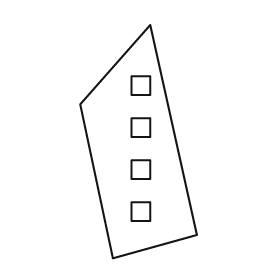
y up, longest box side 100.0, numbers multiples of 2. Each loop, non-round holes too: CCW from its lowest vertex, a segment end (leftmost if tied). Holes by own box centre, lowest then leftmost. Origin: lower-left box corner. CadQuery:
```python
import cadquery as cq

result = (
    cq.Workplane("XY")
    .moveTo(14.0, 0.0)
    .lineTo(50.0, 10.0)
    .lineTo(30.0, 100.0)
    .lineTo(0.0, 66.0)
    .close()
    .moveTo(22.0, 16.0)
    .lineTo(30.0, 16.0)
    .lineTo(30.0, 24.0)
    .lineTo(22.0, 24.0)
    .close()
    .moveTo(22.0, 34.0)
    .lineTo(30.0, 34.0)
    .lineTo(30.0, 42.0)
    .lineTo(22.0, 42.0)
    .close()
    .moveTo(22.0, 52.0)
    .lineTo(30.0, 52.0)
    .lineTo(30.0, 60.0)
    .lineTo(22.0, 60.0)
    .close()
    .moveTo(22.0, 70.0)
    .lineTo(30.0, 70.0)
    .lineTo(30.0, 78.0)
    .lineTo(22.0, 78.0)
    .close()
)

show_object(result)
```